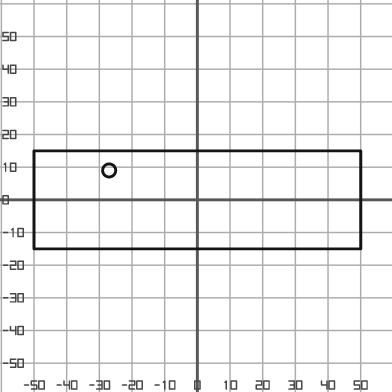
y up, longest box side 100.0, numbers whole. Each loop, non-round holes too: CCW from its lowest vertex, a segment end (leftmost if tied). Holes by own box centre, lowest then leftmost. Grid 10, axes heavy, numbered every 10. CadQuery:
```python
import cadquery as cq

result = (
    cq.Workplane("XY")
    .moveTo(-50.0, -15.0)
    .lineTo(50.0, -15.0)
    .lineTo(50.0, 15.0)
    .lineTo(-50.0, 15.0)
    .close()
    .moveTo(-27.0, 9.0)
    .circle(2.0)
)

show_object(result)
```